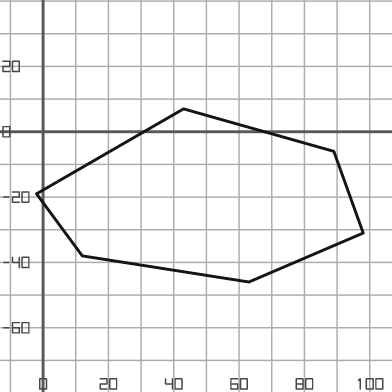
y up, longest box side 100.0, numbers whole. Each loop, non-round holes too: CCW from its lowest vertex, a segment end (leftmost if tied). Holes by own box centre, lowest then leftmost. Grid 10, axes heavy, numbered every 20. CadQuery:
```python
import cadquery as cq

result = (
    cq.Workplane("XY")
    .moveTo(63.0, -46.0)
    .lineTo(98.0, -31.0)
    .lineTo(89.0, -6.0)
    .lineTo(43.0, 7.0)
    .lineTo(-2.0, -19.0)
    .lineTo(12.0, -38.0)
    .close()
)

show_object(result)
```